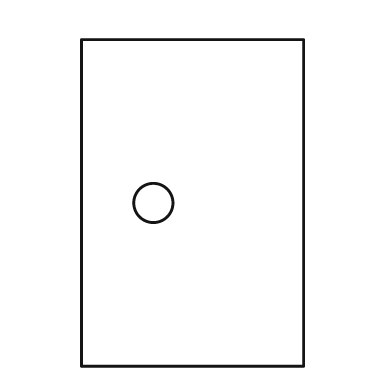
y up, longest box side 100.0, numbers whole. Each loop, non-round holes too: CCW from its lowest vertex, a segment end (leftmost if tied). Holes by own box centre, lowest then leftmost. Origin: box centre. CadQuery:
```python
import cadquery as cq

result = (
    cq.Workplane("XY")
    .moveTo(-34.0, -50.0)
    .lineTo(34.0, -50.0)
    .lineTo(34.0, 50.0)
    .lineTo(-34.0, 50.0)
    .close()
    .moveTo(-12.0, 0.0)
    .circle(6.0)
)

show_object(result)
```